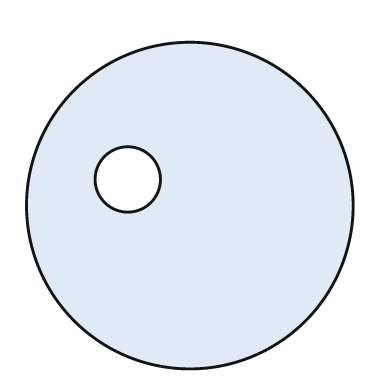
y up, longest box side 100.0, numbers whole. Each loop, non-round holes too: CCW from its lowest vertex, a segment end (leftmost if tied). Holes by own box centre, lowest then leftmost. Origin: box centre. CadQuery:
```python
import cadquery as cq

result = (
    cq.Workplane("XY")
    .moveTo(0.0, 0.0)
    .circle(50.0)
    .moveTo(-19.0, 8.0)
    .circle(10.0)
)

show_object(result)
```